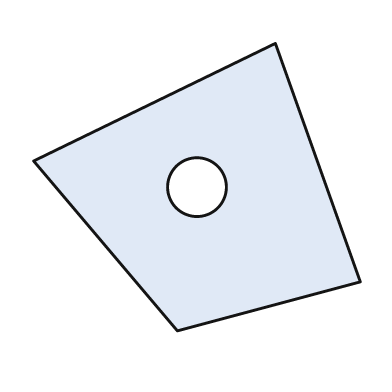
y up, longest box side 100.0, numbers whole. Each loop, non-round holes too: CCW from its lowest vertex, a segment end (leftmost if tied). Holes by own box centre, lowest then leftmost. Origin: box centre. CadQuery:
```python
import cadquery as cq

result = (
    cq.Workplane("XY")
    .moveTo(-6.0, -44.0)
    .lineTo(50.0, -29.0)
    .lineTo(24.0, 44.0)
    .lineTo(-50.0, 8.0)
    .close()
    .moveTo(0.0, 0.0)
    .circle(9.0)
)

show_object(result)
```